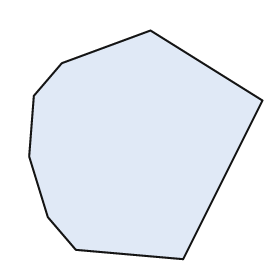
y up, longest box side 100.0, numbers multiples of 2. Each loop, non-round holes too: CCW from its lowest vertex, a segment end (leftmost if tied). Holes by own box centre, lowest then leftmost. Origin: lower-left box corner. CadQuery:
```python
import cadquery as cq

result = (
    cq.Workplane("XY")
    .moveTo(66.0, 0.0)
    .lineTo(100.0, 68.0)
    .lineTo(52.0, 98.0)
    .lineTo(14.0, 84.0)
    .lineTo(2.0, 70.0)
    .lineTo(0.0, 44.0)
    .lineTo(8.0, 18.0)
    .lineTo(20.0, 4.0)
    .close()
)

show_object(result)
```